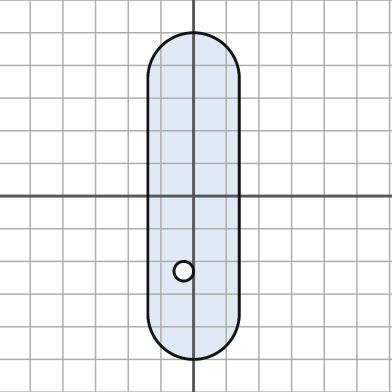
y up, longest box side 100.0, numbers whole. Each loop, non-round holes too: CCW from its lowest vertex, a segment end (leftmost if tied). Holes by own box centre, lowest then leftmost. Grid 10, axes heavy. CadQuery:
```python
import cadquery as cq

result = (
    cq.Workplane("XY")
    .moveTo(-14.0, -36.0)
    .threePointArc((0.0, -50.0), (14.0, -36.0))
    .lineTo(14.0, 36.0)
    .threePointArc((0.0, 50.0), (-14.0, 36.0))
    .close()
    .moveTo(-3.0, -23.0)
    .circle(3.0)
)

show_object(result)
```